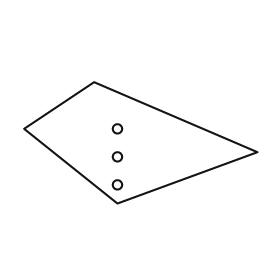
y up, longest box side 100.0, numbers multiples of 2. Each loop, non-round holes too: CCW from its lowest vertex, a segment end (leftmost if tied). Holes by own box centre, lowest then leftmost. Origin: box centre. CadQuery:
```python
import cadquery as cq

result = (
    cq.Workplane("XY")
    .moveTo(-10.0, -26.0)
    .lineTo(50.0, -4.0)
    .lineTo(-20.0, 26.0)
    .lineTo(-50.0, 6.0)
    .close()
    .moveTo(-10.0, -18.0)
    .circle(2.0)
    .moveTo(-10.0, -6.0)
    .circle(2.0)
    .moveTo(-10.0, 6.0)
    .circle(2.0)
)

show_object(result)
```